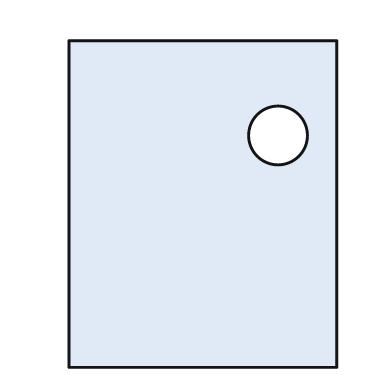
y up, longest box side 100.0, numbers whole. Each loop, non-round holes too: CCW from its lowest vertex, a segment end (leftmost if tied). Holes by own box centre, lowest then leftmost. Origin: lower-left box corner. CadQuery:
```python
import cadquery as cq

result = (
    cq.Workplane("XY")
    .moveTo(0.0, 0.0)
    .lineTo(82.0, 0.0)
    .lineTo(82.0, 100.0)
    .lineTo(0.0, 100.0)
    .close()
    .moveTo(64.0, 71.0)
    .circle(9.0)
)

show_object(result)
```